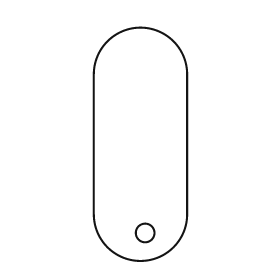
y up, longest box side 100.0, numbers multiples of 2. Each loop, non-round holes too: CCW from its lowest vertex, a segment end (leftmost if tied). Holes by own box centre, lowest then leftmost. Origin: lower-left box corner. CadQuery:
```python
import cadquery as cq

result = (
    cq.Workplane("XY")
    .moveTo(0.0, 20.0)
    .threePointArc((20.0, 0.0), (40.0, 20.0))
    .lineTo(40.0, 80.0)
    .threePointArc((20.0, 100.0), (0.0, 80.0))
    .close()
    .moveTo(22.0, 12.0)
    .circle(4.0)
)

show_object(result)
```